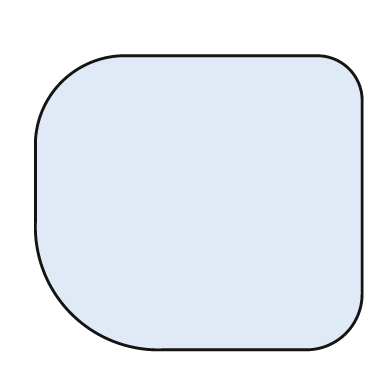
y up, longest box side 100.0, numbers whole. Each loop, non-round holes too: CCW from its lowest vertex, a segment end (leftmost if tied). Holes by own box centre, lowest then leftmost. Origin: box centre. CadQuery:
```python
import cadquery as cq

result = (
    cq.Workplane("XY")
    .moveTo(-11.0, -45.0)
    .lineTo(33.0, -45.0)
    .threePointArc((45.0, -40.0), (50.0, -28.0))
    .lineTo(50.0, 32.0)
    .threePointArc((46.0, 41.0), (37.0, 45.0))
    .lineTo(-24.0, 45.0)
    .threePointArc((-42.0, 37.0), (-50.0, 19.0))
    .lineTo(-50.0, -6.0)
    .threePointArc((-39.0, -34.0), (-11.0, -45.0))
    .close()
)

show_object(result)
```